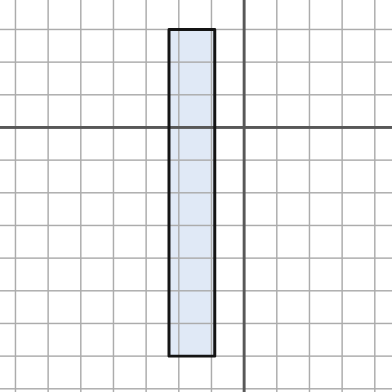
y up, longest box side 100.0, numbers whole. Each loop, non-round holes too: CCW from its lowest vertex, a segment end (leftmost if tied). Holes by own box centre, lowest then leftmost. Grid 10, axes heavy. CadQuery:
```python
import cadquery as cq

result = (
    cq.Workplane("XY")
    .moveTo(-23.0, -70.0)
    .lineTo(-9.0, -70.0)
    .lineTo(-9.0, 30.0)
    .lineTo(-23.0, 30.0)
    .close()
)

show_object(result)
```